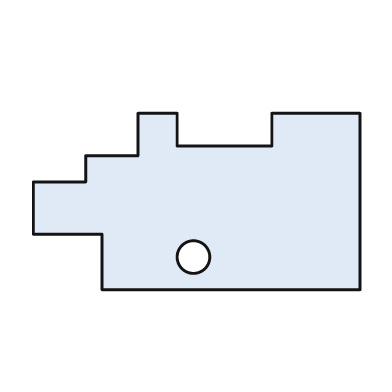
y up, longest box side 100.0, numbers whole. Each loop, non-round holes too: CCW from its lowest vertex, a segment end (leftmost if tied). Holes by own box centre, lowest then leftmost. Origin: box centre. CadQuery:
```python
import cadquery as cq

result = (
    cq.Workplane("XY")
    .moveTo(-29.0, -27.0)
    .lineTo(50.0, -27.0)
    .lineTo(50.0, 27.0)
    .lineTo(23.0, 27.0)
    .lineTo(23.0, 17.0)
    .lineTo(-6.0, 17.0)
    .lineTo(-6.0, 27.0)
    .lineTo(-18.0, 27.0)
    .lineTo(-18.0, 14.0)
    .lineTo(-34.0, 14.0)
    .lineTo(-34.0, 6.0)
    .lineTo(-50.0, 6.0)
    .lineTo(-50.0, -10.0)
    .lineTo(-29.0, -10.0)
    .close()
    .moveTo(-1.0, -17.0)
    .circle(5.0)
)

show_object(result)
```